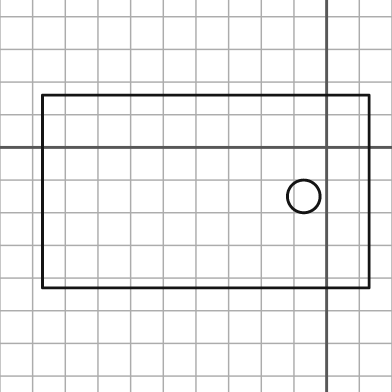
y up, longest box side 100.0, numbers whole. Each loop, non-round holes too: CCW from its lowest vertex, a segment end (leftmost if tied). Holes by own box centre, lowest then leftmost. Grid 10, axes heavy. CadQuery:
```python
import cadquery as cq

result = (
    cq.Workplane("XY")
    .moveTo(-87.0, -43.0)
    .lineTo(13.0, -43.0)
    .lineTo(13.0, 16.0)
    .lineTo(-87.0, 16.0)
    .close()
    .moveTo(-7.0, -15.0)
    .circle(5.0)
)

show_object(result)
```